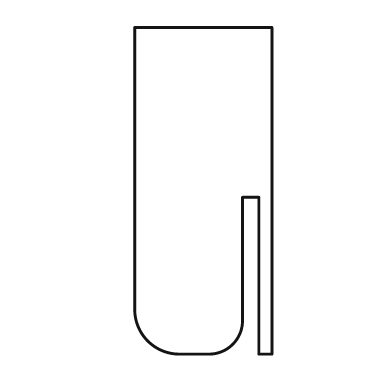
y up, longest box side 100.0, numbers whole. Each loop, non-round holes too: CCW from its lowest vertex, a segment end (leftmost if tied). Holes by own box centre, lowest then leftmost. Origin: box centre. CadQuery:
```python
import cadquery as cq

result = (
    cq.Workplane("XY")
    .moveTo(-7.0, -50.0)
    .lineTo(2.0, -50.0)
    .threePointArc((9.0, -47.0), (12.0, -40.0))
    .lineTo(12.0, -2.0)
    .lineTo(17.0, -2.0)
    .lineTo(17.0, -50.0)
    .lineTo(21.0, -50.0)
    .lineTo(21.0, 50.0)
    .lineTo(-21.0, 50.0)
    .lineTo(-21.0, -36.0)
    .threePointArc((-17.0, -46.0), (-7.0, -50.0))
    .close()
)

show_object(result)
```